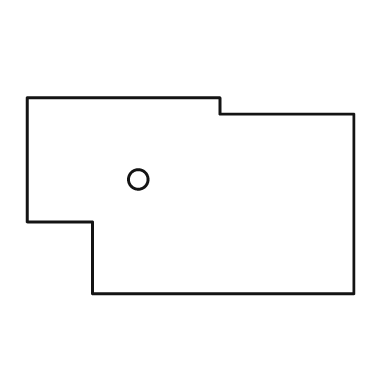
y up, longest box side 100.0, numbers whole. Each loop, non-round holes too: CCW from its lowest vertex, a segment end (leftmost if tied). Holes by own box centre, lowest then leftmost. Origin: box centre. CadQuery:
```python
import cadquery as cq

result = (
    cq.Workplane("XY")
    .moveTo(-30.0, -30.0)
    .lineTo(50.0, -30.0)
    .lineTo(50.0, 25.0)
    .lineTo(9.0, 25.0)
    .lineTo(9.0, 30.0)
    .lineTo(-50.0, 30.0)
    .lineTo(-50.0, -8.0)
    .lineTo(-30.0, -8.0)
    .close()
    .moveTo(-16.0, 5.0)
    .circle(3.0)
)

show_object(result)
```